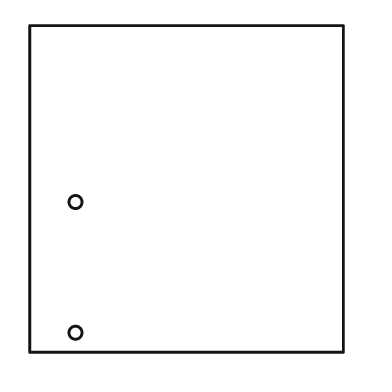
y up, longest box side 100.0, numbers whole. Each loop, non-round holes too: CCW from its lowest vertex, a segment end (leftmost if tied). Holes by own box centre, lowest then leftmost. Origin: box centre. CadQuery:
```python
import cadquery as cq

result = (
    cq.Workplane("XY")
    .moveTo(-48.0, -50.0)
    .lineTo(48.0, -50.0)
    .lineTo(48.0, 50.0)
    .lineTo(-48.0, 50.0)
    .close()
    .moveTo(-34.0, -44.0)
    .circle(2.0)
    .moveTo(-34.0, -4.0)
    .circle(2.0)
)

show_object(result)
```